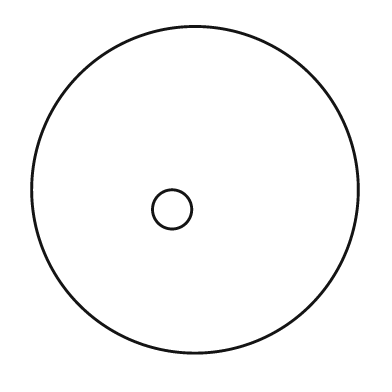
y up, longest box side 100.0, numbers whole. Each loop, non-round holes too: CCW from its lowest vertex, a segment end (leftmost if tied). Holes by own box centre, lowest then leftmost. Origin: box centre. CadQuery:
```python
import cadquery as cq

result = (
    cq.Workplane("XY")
    .moveTo(0.0, 0.0)
    .circle(50.0)
    .moveTo(-7.0, -6.0)
    .circle(6.0)
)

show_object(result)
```